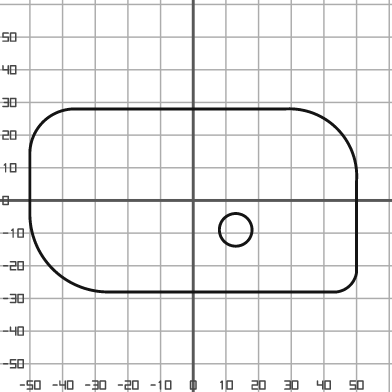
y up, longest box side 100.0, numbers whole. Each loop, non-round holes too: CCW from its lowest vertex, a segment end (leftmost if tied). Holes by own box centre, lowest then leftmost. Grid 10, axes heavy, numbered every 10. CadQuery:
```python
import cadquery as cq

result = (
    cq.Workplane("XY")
    .moveTo(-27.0, -28.0)
    .lineTo(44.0, -28.0)
    .threePointArc((48.0, -26.0), (50.0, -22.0))
    .lineTo(50.0, 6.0)
    .threePointArc((44.0, 22.0), (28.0, 28.0))
    .lineTo(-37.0, 28.0)
    .threePointArc((-46.0, 24.0), (-50.0, 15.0))
    .lineTo(-50.0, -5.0)
    .threePointArc((-43.0, -21.0), (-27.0, -28.0))
    .close()
    .moveTo(13.0, -9.0)
    .circle(5.0)
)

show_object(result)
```